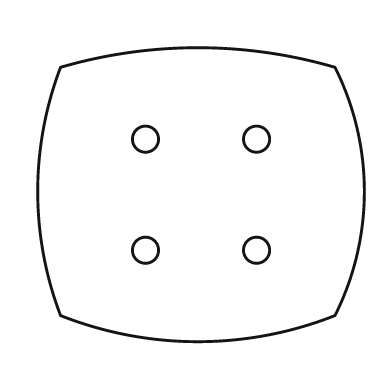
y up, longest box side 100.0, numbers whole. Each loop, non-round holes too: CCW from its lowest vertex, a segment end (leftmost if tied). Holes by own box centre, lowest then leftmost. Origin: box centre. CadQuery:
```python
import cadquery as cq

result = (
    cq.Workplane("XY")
    .moveTo(-43.0, -37.0)
    .threePointArc((-1.0, -45.0), (41.0, -37.0))
    .threePointArc((50.0, 1.0), (41.0, 39.0))
    .threePointArc((-1.0, 45.0), (-43.0, 39.0))
    .threePointArc((-50.0, 1.0), (-43.0, -37.0))
    .close()
    .moveTo(-17.0, -17.0)
    .circle(4.0)
    .moveTo(17.0, -17.0)
    .circle(4.0)
    .moveTo(-17.0, 17.0)
    .circle(4.0)
    .moveTo(17.0, 17.0)
    .circle(4.0)
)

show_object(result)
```